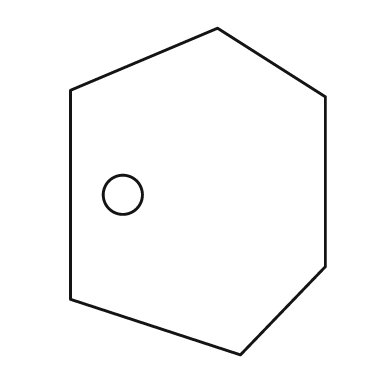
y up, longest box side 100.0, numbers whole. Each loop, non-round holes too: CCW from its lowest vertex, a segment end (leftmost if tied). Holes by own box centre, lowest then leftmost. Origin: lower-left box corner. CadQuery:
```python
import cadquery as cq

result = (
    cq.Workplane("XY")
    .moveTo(52.0, 0.0)
    .lineTo(78.0, 27.0)
    .lineTo(78.0, 79.0)
    .lineTo(45.0, 100.0)
    .lineTo(0.0, 81.0)
    .lineTo(0.0, 17.0)
    .close()
    .moveTo(16.0, 49.0)
    .circle(6.0)
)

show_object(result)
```